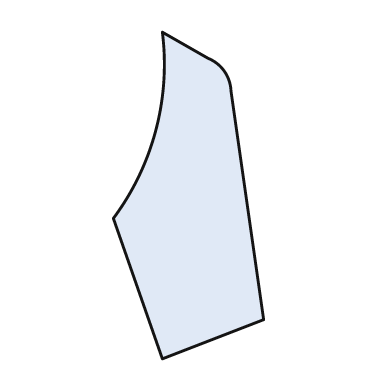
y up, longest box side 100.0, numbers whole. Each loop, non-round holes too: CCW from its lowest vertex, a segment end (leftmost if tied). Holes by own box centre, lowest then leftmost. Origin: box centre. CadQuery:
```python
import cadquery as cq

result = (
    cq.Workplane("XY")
    .moveTo(-8.0, -50.0)
    .lineTo(23.0, -38.0)
    .lineTo(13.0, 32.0)
    .threePointArc((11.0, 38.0), (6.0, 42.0))
    .lineTo(-8.0, 50.0)
    .threePointArc((-10.0, 20.0), (-23.0, -7.0))
    .close()
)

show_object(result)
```